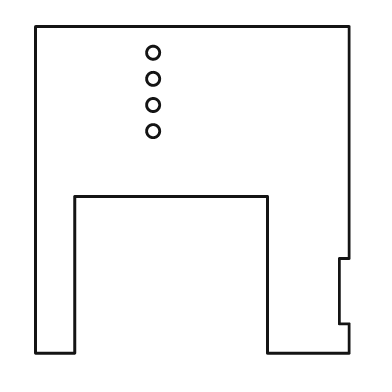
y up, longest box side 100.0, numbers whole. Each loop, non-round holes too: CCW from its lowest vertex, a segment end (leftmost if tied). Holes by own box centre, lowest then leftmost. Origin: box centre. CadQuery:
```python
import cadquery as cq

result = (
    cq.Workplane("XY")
    .moveTo(-48.0, -50.0)
    .lineTo(-36.0, -50.0)
    .lineTo(-36.0, -2.0)
    .lineTo(23.0, -2.0)
    .lineTo(23.0, -50.0)
    .lineTo(48.0, -50.0)
    .lineTo(48.0, -41.0)
    .lineTo(45.0, -41.0)
    .lineTo(45.0, -21.0)
    .lineTo(48.0, -21.0)
    .lineTo(48.0, 50.0)
    .lineTo(-48.0, 50.0)
    .close()
    .moveTo(-12.0, 18.0)
    .circle(2.0)
    .moveTo(-12.0, 26.0)
    .circle(2.0)
    .moveTo(-12.0, 34.0)
    .circle(2.0)
    .moveTo(-12.0, 42.0)
    .circle(2.0)
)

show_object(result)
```